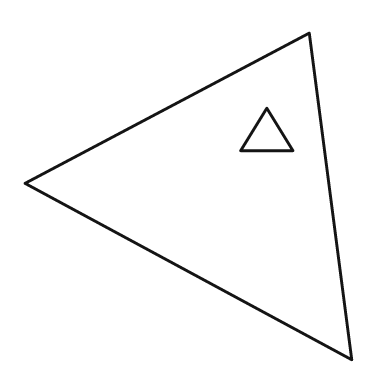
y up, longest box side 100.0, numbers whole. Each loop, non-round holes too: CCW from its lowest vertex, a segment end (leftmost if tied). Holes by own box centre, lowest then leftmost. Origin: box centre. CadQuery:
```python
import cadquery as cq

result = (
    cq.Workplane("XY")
    .moveTo(50.0, -50.0)
    .lineTo(37.0, 50.0)
    .lineTo(-50.0, 4.0)
    .close()
    .moveTo(16.0, 14.0)
    .lineTo(32.0, 14.0)
    .lineTo(24.0, 27.0)
    .close()
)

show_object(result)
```